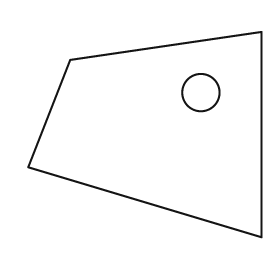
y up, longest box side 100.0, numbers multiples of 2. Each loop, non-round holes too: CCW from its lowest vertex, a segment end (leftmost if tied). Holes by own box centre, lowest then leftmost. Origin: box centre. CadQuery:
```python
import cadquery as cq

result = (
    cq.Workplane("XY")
    .moveTo(50.0, -44.0)
    .lineTo(50.0, 44.0)
    .lineTo(-32.0, 32.0)
    .lineTo(-50.0, -14.0)
    .close()
    .moveTo(24.0, 18.0)
    .circle(8.0)
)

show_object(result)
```